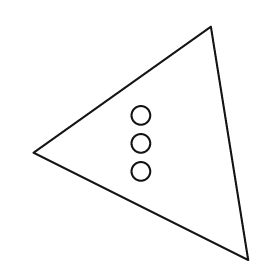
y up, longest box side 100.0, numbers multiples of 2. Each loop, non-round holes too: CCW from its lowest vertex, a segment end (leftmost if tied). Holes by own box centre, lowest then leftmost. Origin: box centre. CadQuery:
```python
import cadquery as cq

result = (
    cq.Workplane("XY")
    .moveTo(46.0, -50.0)
    .lineTo(30.0, 50.0)
    .lineTo(-46.0, -4.0)
    .close()
    .moveTo(0.0, -12.0)
    .circle(4.0)
    .moveTo(0.0, 0.0)
    .circle(4.0)
    .moveTo(0.0, 12.0)
    .circle(4.0)
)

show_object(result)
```